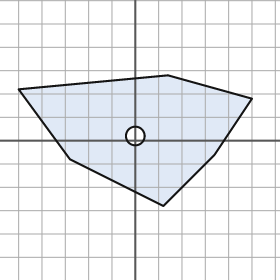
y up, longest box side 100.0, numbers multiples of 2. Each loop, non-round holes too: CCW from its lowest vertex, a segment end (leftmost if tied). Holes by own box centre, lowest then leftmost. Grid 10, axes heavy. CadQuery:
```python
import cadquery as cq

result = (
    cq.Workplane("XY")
    .moveTo(12.0, -28.0)
    .lineTo(34.0, -6.0)
    .lineTo(50.0, 18.0)
    .lineTo(14.0, 28.0)
    .lineTo(-50.0, 22.0)
    .lineTo(-28.0, -8.0)
    .close()
    .moveTo(0.0, 2.0)
    .circle(4.0)
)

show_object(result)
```